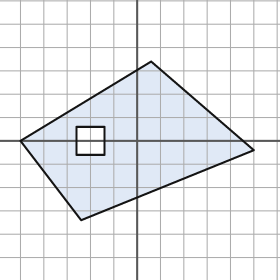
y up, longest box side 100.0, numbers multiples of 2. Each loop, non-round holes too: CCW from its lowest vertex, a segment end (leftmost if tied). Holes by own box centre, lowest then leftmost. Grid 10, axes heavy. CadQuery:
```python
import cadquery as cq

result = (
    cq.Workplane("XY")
    .moveTo(-24.0, -34.0)
    .lineTo(50.0, -4.0)
    .lineTo(6.0, 34.0)
    .lineTo(-50.0, 0.0)
    .close()
    .moveTo(-26.0, -6.0)
    .lineTo(-14.0, -6.0)
    .lineTo(-14.0, 6.0)
    .lineTo(-26.0, 6.0)
    .close()
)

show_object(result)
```